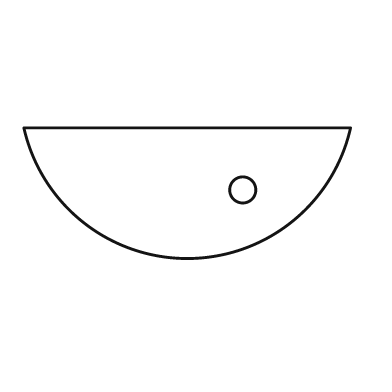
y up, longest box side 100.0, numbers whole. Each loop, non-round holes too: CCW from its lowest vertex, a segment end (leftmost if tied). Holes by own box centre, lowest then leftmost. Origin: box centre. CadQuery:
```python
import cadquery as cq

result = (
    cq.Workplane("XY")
    .moveTo(-50.0, 20.0)
    .threePointArc((0.0, -20.0), (50.0, 20.0))
    .close()
    .moveTo(17.0, 1.0)
    .circle(4.0)
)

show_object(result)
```